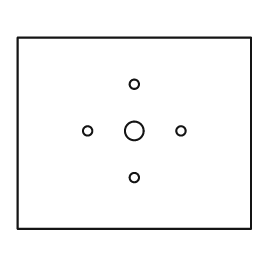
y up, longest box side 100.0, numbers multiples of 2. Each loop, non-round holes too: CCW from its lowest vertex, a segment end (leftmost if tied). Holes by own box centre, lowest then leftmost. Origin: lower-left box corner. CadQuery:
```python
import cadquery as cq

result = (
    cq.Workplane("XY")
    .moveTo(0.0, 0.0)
    .lineTo(100.0, 0.0)
    .lineTo(100.0, 82.0)
    .lineTo(0.0, 82.0)
    .close()
    .moveTo(50.0, 22.0)
    .circle(2.0)
    .moveTo(30.0, 42.0)
    .circle(2.0)
    .moveTo(50.0, 42.0)
    .circle(4.0)
    .moveTo(70.0, 42.0)
    .circle(2.0)
    .moveTo(50.0, 62.0)
    .circle(2.0)
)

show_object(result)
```